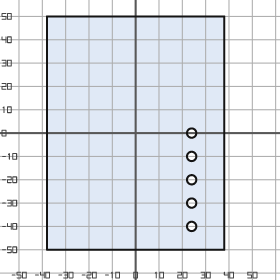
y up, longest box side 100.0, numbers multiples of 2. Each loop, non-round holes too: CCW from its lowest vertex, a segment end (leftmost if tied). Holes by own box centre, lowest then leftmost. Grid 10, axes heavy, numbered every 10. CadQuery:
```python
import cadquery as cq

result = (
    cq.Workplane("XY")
    .moveTo(-38.0, -50.0)
    .lineTo(38.0, -50.0)
    .lineTo(38.0, 50.0)
    .lineTo(-38.0, 50.0)
    .close()
    .moveTo(24.0, -40.0)
    .circle(2.0)
    .moveTo(24.0, -30.0)
    .circle(2.0)
    .moveTo(24.0, -20.0)
    .circle(2.0)
    .moveTo(24.0, -10.0)
    .circle(2.0)
    .moveTo(24.0, 0.0)
    .circle(2.0)
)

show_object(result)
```